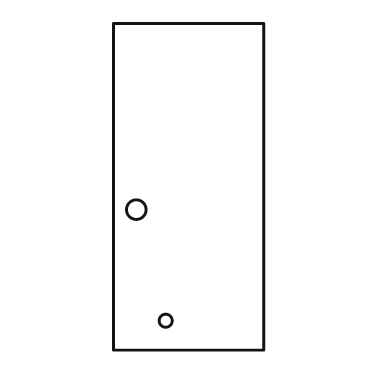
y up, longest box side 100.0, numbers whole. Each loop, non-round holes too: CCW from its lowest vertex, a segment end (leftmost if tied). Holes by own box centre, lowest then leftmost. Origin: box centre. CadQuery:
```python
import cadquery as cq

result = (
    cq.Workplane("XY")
    .moveTo(-23.0, -50.0)
    .lineTo(23.0, -50.0)
    .lineTo(23.0, 50.0)
    .lineTo(-23.0, 50.0)
    .close()
    .moveTo(-7.0, -41.0)
    .circle(2.0)
    .moveTo(-16.0, -7.0)
    .circle(3.0)
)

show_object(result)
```